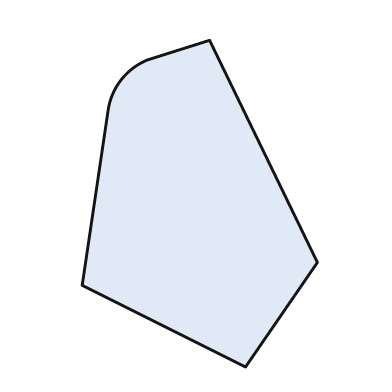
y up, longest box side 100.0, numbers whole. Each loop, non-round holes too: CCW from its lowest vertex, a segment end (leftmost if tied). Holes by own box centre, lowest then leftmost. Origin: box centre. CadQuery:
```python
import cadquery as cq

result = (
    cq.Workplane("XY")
    .moveTo(14.0, -50.0)
    .lineTo(36.0, -18.0)
    .lineTo(3.0, 50.0)
    .lineTo(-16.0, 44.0)
    .threePointArc((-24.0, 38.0), (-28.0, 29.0))
    .lineTo(-36.0, -25.0)
    .close()
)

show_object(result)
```